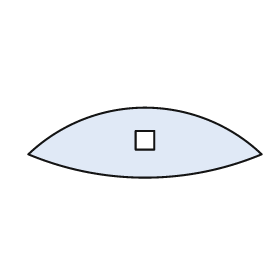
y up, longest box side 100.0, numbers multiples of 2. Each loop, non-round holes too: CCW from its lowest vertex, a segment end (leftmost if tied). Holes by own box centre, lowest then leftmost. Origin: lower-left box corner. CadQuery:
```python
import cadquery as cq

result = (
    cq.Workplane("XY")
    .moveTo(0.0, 10.0)
    .threePointArc((50.0, 0.0), (100.0, 10.0))
    .threePointArc((50.0, 30.0), (0.0, 10.0))
    .close()
    .moveTo(46.0, 12.0)
    .lineTo(54.0, 12.0)
    .lineTo(54.0, 20.0)
    .lineTo(46.0, 20.0)
    .close()
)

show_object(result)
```